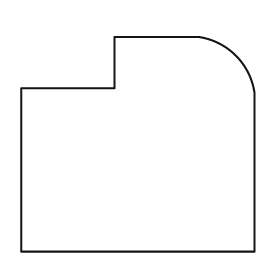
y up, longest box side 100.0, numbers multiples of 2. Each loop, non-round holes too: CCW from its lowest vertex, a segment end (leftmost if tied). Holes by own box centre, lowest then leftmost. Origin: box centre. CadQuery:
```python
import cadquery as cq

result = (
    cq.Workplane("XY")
    .moveTo(-50.0, -46.0)
    .lineTo(50.0, -46.0)
    .lineTo(50.0, 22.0)
    .threePointArc((42.0, 38.0), (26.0, 46.0))
    .lineTo(-10.0, 46.0)
    .lineTo(-10.0, 24.0)
    .lineTo(-50.0, 24.0)
    .close()
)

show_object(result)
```